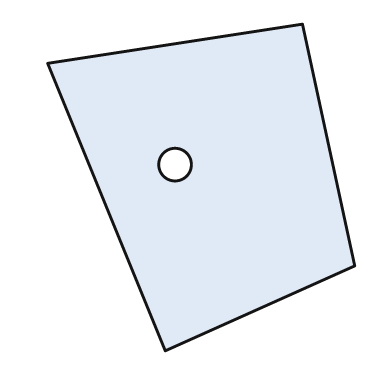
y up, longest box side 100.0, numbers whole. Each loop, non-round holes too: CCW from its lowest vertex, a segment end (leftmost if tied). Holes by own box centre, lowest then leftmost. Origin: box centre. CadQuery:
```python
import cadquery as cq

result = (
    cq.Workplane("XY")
    .moveTo(-11.0, -50.0)
    .lineTo(47.0, -24.0)
    .lineTo(31.0, 50.0)
    .lineTo(-47.0, 38.0)
    .close()
    .moveTo(-8.0, 7.0)
    .circle(5.0)
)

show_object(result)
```